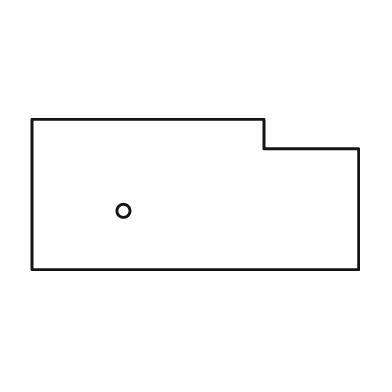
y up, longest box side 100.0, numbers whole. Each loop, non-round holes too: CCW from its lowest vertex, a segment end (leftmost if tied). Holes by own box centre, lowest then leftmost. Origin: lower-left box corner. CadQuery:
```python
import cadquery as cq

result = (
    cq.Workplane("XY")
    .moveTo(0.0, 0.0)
    .lineTo(100.0, 0.0)
    .lineTo(100.0, 37.0)
    .lineTo(71.0, 37.0)
    .lineTo(71.0, 46.0)
    .lineTo(0.0, 46.0)
    .close()
    .moveTo(28.0, 18.0)
    .circle(2.0)
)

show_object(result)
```